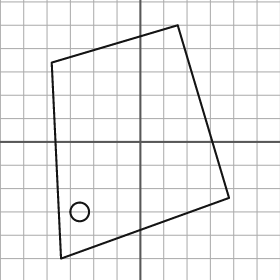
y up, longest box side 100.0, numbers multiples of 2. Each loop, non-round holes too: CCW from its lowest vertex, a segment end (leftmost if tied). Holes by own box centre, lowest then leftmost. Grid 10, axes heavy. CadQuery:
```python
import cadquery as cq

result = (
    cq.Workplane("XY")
    .moveTo(-34.0, -50.0)
    .lineTo(38.0, -24.0)
    .lineTo(16.0, 50.0)
    .lineTo(-38.0, 34.0)
    .close()
    .moveTo(-26.0, -30.0)
    .circle(4.0)
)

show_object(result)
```